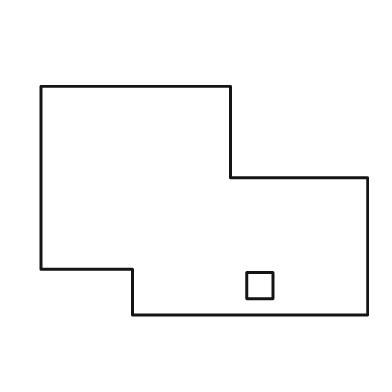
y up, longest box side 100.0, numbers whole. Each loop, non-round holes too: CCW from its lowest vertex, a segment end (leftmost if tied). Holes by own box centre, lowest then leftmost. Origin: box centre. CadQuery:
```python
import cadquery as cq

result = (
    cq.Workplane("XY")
    .moveTo(-22.0, -35.0)
    .lineTo(50.0, -35.0)
    .lineTo(50.0, 7.0)
    .lineTo(8.0, 7.0)
    .lineTo(8.0, 35.0)
    .lineTo(-50.0, 35.0)
    .lineTo(-50.0, -21.0)
    .lineTo(-22.0, -21.0)
    .close()
    .moveTo(13.0, -30.0)
    .lineTo(21.0, -30.0)
    .lineTo(21.0, -22.0)
    .lineTo(13.0, -22.0)
    .close()
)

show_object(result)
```